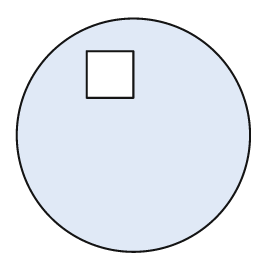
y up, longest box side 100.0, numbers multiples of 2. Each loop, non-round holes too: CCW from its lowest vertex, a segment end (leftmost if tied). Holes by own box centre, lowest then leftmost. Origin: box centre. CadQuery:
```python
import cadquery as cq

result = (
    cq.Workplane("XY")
    .moveTo(0.0, 0.0)
    .circle(50.0)
    .moveTo(-20.0, 16.0)
    .lineTo(0.0, 16.0)
    .lineTo(0.0, 36.0)
    .lineTo(-20.0, 36.0)
    .close()
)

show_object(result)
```